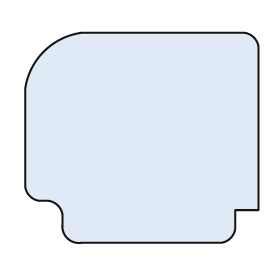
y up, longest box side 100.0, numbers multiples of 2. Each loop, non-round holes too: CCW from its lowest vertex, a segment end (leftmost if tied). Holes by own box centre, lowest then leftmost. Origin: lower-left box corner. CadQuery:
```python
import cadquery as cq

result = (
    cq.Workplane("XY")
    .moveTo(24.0, 0.0)
    .lineTo(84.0, 0.0)
    .threePointArc((88.0, 2.0), (90.0, 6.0))
    .lineTo(90.0, 14.0)
    .lineTo(100.0, 14.0)
    .lineTo(100.0, 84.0)
    .threePointArc((98.0, 88.0), (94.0, 90.0))
    .lineTo(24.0, 90.0)
    .threePointArc((8.0, 82.0), (0.0, 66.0))
    .lineTo(0.0, 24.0)
    .threePointArc((2.0, 20.0), (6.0, 18.0))
    .lineTo(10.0, 18.0)
    .threePointArc((14.0, 16.0), (16.0, 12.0))
    .lineTo(16.0, 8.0)
    .threePointArc((18.0, 2.0), (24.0, 0.0))
    .close()
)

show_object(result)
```